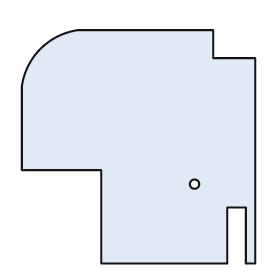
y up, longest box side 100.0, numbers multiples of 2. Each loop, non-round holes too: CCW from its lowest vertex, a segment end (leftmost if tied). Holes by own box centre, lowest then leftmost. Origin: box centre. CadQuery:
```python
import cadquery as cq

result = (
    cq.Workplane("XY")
    .moveTo(-16.0, -50.0)
    .lineTo(38.0, -50.0)
    .lineTo(38.0, -26.0)
    .lineTo(46.0, -26.0)
    .lineTo(46.0, -50.0)
    .lineTo(50.0, -50.0)
    .lineTo(50.0, 38.0)
    .lineTo(32.0, 38.0)
    .lineTo(32.0, 50.0)
    .lineTo(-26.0, 50.0)
    .threePointArc((-42.0, 42.0), (-50.0, 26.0))
    .lineTo(-50.0, -10.0)
    .lineTo(-16.0, -10.0)
    .close()
    .moveTo(24.0, -16.0)
    .circle(2.0)
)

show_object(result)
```